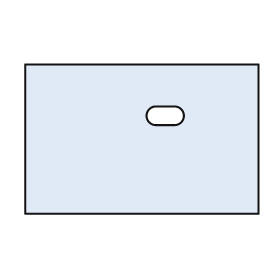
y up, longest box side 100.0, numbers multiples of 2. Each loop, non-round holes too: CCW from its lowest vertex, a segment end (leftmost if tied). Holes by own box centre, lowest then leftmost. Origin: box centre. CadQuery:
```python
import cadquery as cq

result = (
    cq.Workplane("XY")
    .moveTo(-50.0, -32.0)
    .lineTo(50.0, -32.0)
    .lineTo(50.0, 32.0)
    .lineTo(-50.0, 32.0)
    .close()
    .moveTo(6.0, 6.0)
    .lineTo(14.0, 6.0)
    .threePointArc((18.0, 10.0), (14.0, 14.0))
    .lineTo(6.0, 14.0)
    .threePointArc((2.0, 10.0), (6.0, 6.0))
    .close()
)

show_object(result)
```